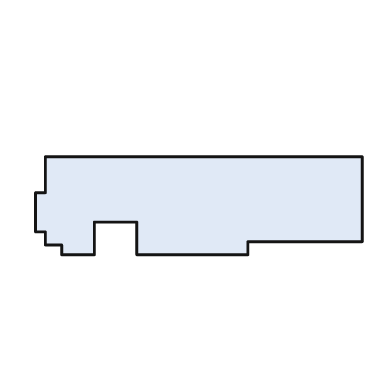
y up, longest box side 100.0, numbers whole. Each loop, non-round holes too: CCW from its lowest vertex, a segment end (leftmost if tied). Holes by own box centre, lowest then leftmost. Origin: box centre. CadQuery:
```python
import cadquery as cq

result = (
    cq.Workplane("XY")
    .moveTo(-42.0, -15.0)
    .lineTo(-32.0, -15.0)
    .lineTo(-32.0, -5.0)
    .lineTo(-19.0, -5.0)
    .lineTo(-19.0, -15.0)
    .lineTo(15.0, -15.0)
    .lineTo(15.0, -11.0)
    .lineTo(50.0, -11.0)
    .lineTo(50.0, 15.0)
    .lineTo(-47.0, 15.0)
    .lineTo(-47.0, 4.0)
    .lineTo(-50.0, 4.0)
    .lineTo(-50.0, -8.0)
    .lineTo(-47.0, -8.0)
    .lineTo(-47.0, -12.0)
    .lineTo(-42.0, -12.0)
    .close()
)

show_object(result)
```